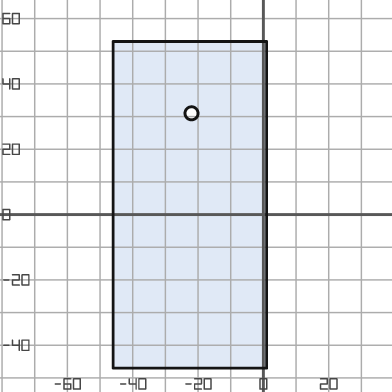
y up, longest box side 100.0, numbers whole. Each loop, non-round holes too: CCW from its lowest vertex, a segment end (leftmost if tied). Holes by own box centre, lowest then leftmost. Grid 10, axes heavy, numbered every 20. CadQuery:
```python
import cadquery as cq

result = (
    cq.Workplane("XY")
    .moveTo(-46.0, -47.0)
    .lineTo(1.0, -47.0)
    .lineTo(1.0, 53.0)
    .lineTo(-46.0, 53.0)
    .close()
    .moveTo(-22.0, 31.0)
    .circle(2.0)
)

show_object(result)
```